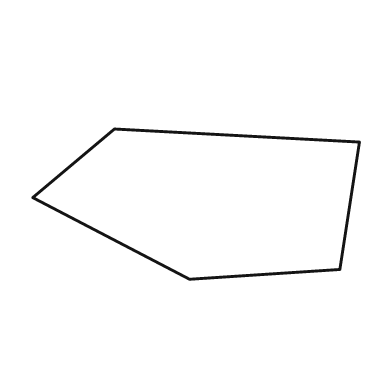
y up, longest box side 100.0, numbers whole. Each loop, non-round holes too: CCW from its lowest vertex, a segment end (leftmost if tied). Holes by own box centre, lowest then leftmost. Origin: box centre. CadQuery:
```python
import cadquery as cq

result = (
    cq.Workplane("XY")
    .moveTo(-2.0, -23.0)
    .lineTo(44.0, -20.0)
    .lineTo(50.0, 19.0)
    .lineTo(-25.0, 23.0)
    .lineTo(-50.0, 2.0)
    .close()
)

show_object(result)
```